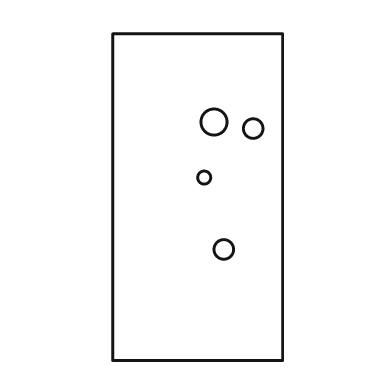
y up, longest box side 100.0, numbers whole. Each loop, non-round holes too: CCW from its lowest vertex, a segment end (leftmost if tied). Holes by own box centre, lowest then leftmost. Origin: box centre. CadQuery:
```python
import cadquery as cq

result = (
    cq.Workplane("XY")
    .moveTo(-26.0, -50.0)
    .lineTo(26.0, -50.0)
    .lineTo(26.0, 50.0)
    .lineTo(-26.0, 50.0)
    .close()
    .moveTo(8.0, -16.0)
    .circle(3.0)
    .moveTo(2.0, 6.0)
    .circle(2.0)
    .moveTo(17.0, 21.0)
    .circle(3.0)
    .moveTo(5.0, 23.0)
    .circle(4.0)
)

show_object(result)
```